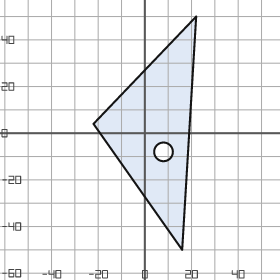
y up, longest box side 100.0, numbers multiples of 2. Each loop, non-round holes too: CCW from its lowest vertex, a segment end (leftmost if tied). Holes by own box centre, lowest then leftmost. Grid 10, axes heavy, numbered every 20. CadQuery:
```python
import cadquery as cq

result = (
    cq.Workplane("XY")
    .moveTo(16.0, -50.0)
    .lineTo(22.0, 50.0)
    .lineTo(-22.0, 4.0)
    .close()
    .moveTo(8.0, -8.0)
    .circle(4.0)
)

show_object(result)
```